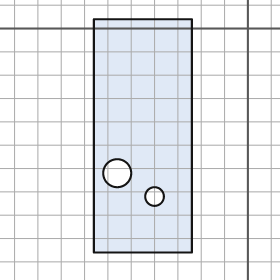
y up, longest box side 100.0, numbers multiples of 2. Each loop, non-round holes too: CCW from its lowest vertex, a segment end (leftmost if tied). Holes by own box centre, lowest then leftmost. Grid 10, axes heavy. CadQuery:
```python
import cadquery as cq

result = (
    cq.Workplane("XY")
    .moveTo(-66.0, -96.0)
    .lineTo(-24.0, -96.0)
    .lineTo(-24.0, 4.0)
    .lineTo(-66.0, 4.0)
    .close()
    .moveTo(-40.0, -72.0)
    .circle(4.0)
    .moveTo(-56.0, -62.0)
    .circle(6.0)
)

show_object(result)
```